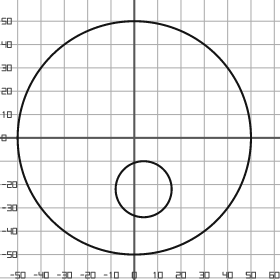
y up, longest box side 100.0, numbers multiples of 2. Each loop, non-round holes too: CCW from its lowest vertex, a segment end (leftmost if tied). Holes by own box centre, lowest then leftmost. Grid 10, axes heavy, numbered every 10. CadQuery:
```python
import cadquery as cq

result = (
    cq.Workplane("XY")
    .moveTo(0.0, 0.0)
    .circle(50.0)
    .moveTo(4.0, -22.0)
    .circle(12.0)
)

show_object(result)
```